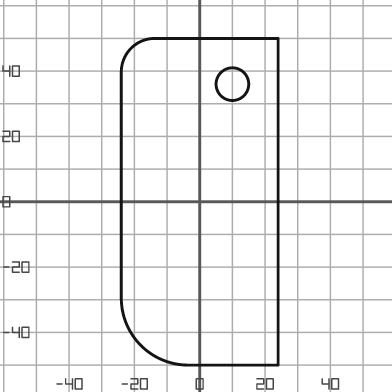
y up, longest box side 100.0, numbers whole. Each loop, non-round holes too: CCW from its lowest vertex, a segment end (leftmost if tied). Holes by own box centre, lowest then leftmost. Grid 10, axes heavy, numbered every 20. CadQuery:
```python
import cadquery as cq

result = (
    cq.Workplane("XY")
    .moveTo(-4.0, -50.0)
    .lineTo(24.0, -50.0)
    .lineTo(24.0, 50.0)
    .lineTo(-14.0, 50.0)
    .threePointArc((-21.0, 47.0), (-24.0, 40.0))
    .lineTo(-24.0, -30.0)
    .threePointArc((-18.0, -44.0), (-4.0, -50.0))
    .close()
    .moveTo(10.0, 36.0)
    .circle(5.0)
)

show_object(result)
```